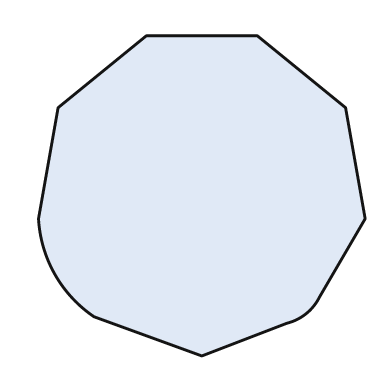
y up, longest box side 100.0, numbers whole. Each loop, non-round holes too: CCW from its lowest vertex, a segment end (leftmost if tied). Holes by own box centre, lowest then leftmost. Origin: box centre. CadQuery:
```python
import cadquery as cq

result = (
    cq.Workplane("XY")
    .moveTo(0.0, -49.0)
    .lineTo(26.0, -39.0)
    .threePointArc((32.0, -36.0), (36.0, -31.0))
    .lineTo(50.0, -7.0)
    .lineTo(44.0, 27.0)
    .lineTo(17.0, 49.0)
    .lineTo(-17.0, 49.0)
    .lineTo(-44.0, 27.0)
    .lineTo(-50.0, -7.0)
    .threePointArc((-45.0, -24.0), (-33.0, -37.0))
    .close()
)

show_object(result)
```